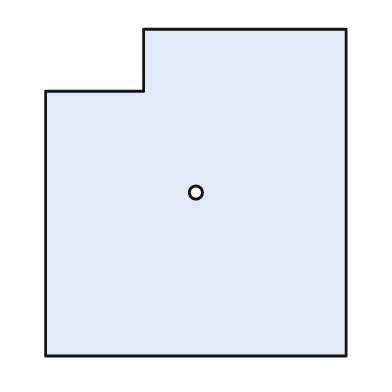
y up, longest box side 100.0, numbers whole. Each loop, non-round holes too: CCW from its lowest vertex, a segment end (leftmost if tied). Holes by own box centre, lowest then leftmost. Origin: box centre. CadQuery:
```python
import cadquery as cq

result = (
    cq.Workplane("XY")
    .moveTo(-46.0, -50.0)
    .lineTo(46.0, -50.0)
    .lineTo(46.0, 50.0)
    .lineTo(-16.0, 50.0)
    .lineTo(-16.0, 31.0)
    .lineTo(-46.0, 31.0)
    .close()
    .moveTo(0.0, 0.0)
    .circle(2.0)
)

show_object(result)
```